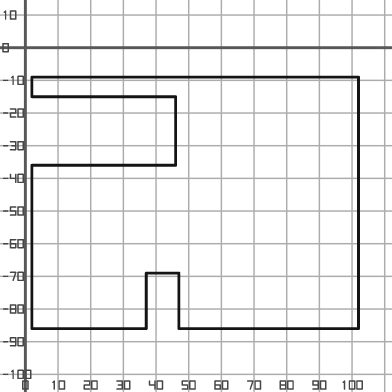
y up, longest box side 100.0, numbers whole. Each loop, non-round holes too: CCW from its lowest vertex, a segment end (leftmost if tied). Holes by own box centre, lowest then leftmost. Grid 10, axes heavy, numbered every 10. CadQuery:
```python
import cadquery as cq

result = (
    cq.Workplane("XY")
    .moveTo(2.0, -86.0)
    .lineTo(37.0, -86.0)
    .lineTo(37.0, -69.0)
    .lineTo(47.0, -69.0)
    .lineTo(47.0, -86.0)
    .lineTo(102.0, -86.0)
    .lineTo(102.0, -9.0)
    .lineTo(2.0, -9.0)
    .lineTo(2.0, -15.0)
    .lineTo(46.0, -15.0)
    .lineTo(46.0, -36.0)
    .lineTo(2.0, -36.0)
    .close()
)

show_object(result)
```